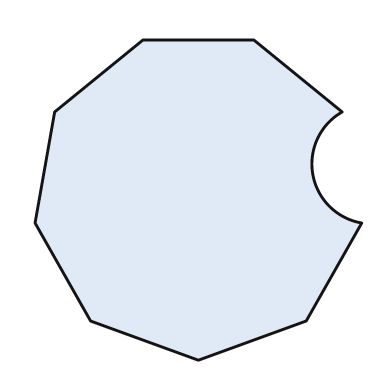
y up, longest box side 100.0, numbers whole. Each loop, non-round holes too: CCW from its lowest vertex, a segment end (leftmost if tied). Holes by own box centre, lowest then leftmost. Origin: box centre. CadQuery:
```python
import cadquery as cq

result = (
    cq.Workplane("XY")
    .moveTo(0.0, -49.0)
    .lineTo(33.0, -37.0)
    .lineTo(50.0, -7.0)
    .threePointArc((35.0, 8.0), (44.0, 27.0))
    .lineTo(17.0, 49.0)
    .lineTo(-17.0, 49.0)
    .lineTo(-44.0, 27.0)
    .lineTo(-50.0, -7.0)
    .lineTo(-33.0, -37.0)
    .close()
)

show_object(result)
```